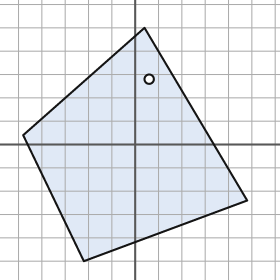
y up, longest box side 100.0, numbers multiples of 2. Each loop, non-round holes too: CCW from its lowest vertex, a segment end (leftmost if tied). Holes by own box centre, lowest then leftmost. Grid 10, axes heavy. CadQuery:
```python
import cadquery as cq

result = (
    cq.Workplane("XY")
    .moveTo(-22.0, -50.0)
    .lineTo(48.0, -24.0)
    .lineTo(4.0, 50.0)
    .lineTo(-48.0, 4.0)
    .close()
    .moveTo(6.0, 28.0)
    .circle(2.0)
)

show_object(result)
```